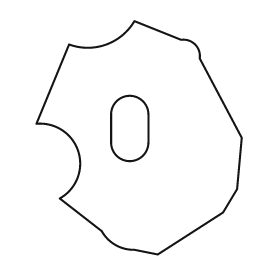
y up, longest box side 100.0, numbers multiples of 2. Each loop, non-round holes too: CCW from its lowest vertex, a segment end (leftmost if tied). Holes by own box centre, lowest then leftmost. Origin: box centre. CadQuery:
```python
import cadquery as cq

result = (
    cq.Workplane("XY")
    .moveTo(8.0, -50.0)
    .lineTo(36.0, -32.0)
    .lineTo(42.0, -22.0)
    .lineTo(44.0, 0.0)
    .lineTo(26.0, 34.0)
    .threePointArc((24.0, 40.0), (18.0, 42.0))
    .lineTo(-2.0, 50.0)
    .threePointArc((-14.0, 40.0), (-30.0, 40.0))
    .lineTo(-44.0, 6.0)
    .threePointArc((-26.0, -6.0), (-34.0, -26.0))
    .lineTo(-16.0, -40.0)
    .threePointArc((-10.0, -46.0), (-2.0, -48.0))
    .close()
    .moveTo(-12.0, -2.0)
    .threePointArc((-4.0, -10.0), (4.0, -2.0))
    .lineTo(4.0, 10.0)
    .threePointArc((-4.0, 18.0), (-12.0, 10.0))
    .close()
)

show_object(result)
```